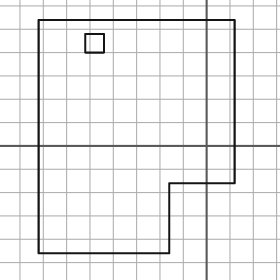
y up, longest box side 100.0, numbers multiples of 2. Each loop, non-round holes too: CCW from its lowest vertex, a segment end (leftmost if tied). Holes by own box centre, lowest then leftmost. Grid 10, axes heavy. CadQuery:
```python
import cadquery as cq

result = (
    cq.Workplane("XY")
    .moveTo(-72.0, -46.0)
    .lineTo(-16.0, -46.0)
    .lineTo(-16.0, -16.0)
    .lineTo(12.0, -16.0)
    .lineTo(12.0, 54.0)
    .lineTo(-72.0, 54.0)
    .close()
    .moveTo(-52.0, 40.0)
    .lineTo(-44.0, 40.0)
    .lineTo(-44.0, 48.0)
    .lineTo(-52.0, 48.0)
    .close()
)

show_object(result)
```